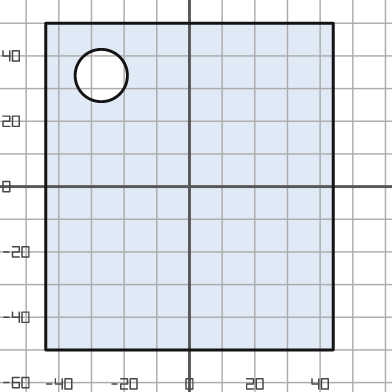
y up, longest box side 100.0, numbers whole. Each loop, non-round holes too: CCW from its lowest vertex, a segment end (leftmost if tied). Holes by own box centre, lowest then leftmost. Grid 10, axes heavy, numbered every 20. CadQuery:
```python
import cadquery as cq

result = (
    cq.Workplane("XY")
    .moveTo(-44.0, -50.0)
    .lineTo(44.0, -50.0)
    .lineTo(44.0, 50.0)
    .lineTo(-44.0, 50.0)
    .close()
    .moveTo(-27.0, 34.0)
    .circle(8.0)
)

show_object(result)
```